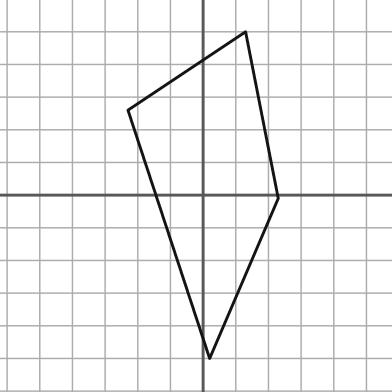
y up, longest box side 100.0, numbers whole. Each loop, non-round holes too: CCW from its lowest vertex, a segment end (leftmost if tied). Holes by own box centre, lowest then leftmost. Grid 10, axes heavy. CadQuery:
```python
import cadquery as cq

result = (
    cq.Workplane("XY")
    .moveTo(2.0, -50.0)
    .lineTo(23.0, -1.0)
    .lineTo(13.0, 50.0)
    .lineTo(-23.0, 26.0)
    .close()
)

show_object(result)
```